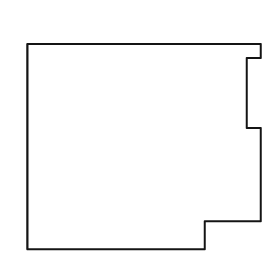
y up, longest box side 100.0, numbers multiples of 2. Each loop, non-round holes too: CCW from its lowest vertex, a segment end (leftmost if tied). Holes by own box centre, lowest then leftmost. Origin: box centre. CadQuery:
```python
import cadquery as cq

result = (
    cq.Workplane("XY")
    .moveTo(-50.0, -44.0)
    .lineTo(26.0, -44.0)
    .lineTo(26.0, -32.0)
    .lineTo(50.0, -32.0)
    .lineTo(50.0, 8.0)
    .lineTo(44.0, 8.0)
    .lineTo(44.0, 38.0)
    .lineTo(50.0, 38.0)
    .lineTo(50.0, 44.0)
    .lineTo(-50.0, 44.0)
    .close()
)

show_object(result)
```